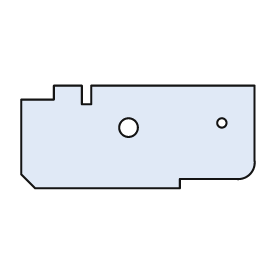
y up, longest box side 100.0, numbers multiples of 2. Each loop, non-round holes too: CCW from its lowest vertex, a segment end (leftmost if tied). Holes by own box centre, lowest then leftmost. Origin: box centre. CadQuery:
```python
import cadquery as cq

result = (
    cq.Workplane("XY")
    .moveTo(-44.0, -22.0)
    .lineTo(18.0, -22.0)
    .lineTo(18.0, -18.0)
    .lineTo(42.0, -18.0)
    .threePointArc((48.0, -16.0), (50.0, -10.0))
    .lineTo(50.0, 22.0)
    .lineTo(-20.0, 22.0)
    .lineTo(-20.0, 14.0)
    .lineTo(-24.0, 14.0)
    .lineTo(-24.0, 22.0)
    .lineTo(-36.0, 22.0)
    .lineTo(-36.0, 16.0)
    .lineTo(-50.0, 16.0)
    .lineTo(-50.0, -16.0)
    .close()
    .moveTo(-4.0, 4.0)
    .circle(4.0)
    .moveTo(36.0, 6.0)
    .circle(2.0)
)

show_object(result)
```